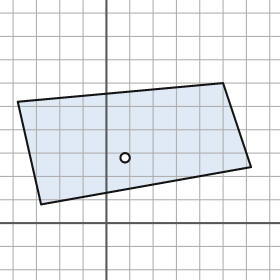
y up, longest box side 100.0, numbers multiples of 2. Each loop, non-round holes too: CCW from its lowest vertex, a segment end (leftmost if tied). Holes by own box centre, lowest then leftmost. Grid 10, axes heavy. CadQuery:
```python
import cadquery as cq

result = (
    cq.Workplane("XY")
    .moveTo(-28.0, 8.0)
    .lineTo(62.0, 24.0)
    .lineTo(50.0, 60.0)
    .lineTo(-38.0, 52.0)
    .close()
    .moveTo(8.0, 28.0)
    .circle(2.0)
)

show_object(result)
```